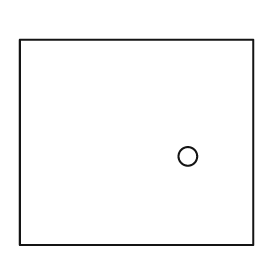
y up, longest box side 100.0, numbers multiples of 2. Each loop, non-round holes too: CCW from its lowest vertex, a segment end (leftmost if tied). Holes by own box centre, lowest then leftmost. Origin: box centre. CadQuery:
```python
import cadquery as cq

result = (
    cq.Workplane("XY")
    .moveTo(-50.0, -44.0)
    .lineTo(50.0, -44.0)
    .lineTo(50.0, 44.0)
    .lineTo(-50.0, 44.0)
    .close()
    .moveTo(22.0, -6.0)
    .circle(4.0)
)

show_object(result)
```